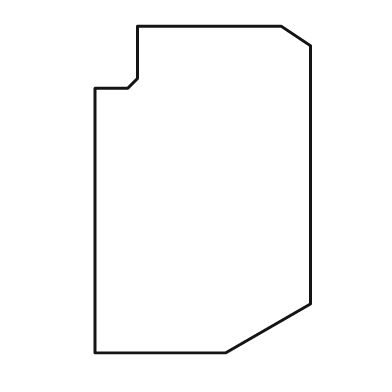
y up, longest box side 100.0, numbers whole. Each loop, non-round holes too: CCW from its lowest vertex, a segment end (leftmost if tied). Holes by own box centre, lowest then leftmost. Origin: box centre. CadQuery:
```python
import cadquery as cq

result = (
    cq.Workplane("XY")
    .moveTo(-33.0, -50.0)
    .lineTo(7.0, -50.0)
    .lineTo(33.0, -35.0)
    .lineTo(33.0, 44.0)
    .lineTo(24.0, 50.0)
    .lineTo(-20.0, 50.0)
    .lineTo(-20.0, 34.0)
    .lineTo(-23.0, 31.0)
    .lineTo(-33.0, 31.0)
    .close()
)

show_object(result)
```